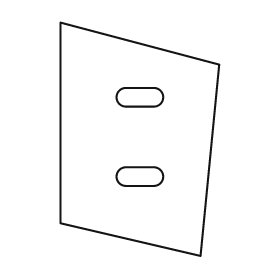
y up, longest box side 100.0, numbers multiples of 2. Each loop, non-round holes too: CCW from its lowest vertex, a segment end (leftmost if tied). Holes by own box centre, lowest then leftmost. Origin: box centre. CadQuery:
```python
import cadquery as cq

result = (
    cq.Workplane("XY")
    .moveTo(26.0, -50.0)
    .lineTo(34.0, 32.0)
    .lineTo(-34.0, 50.0)
    .lineTo(-34.0, -36.0)
    .close()
    .moveTo(-6.0, -20.0)
    .lineTo(6.0, -20.0)
    .threePointArc((10.0, -16.0), (6.0, -12.0))
    .lineTo(-6.0, -12.0)
    .threePointArc((-10.0, -16.0), (-6.0, -20.0))
    .close()
    .moveTo(-6.0, 14.0)
    .lineTo(6.0, 14.0)
    .threePointArc((10.0, 18.0), (6.0, 22.0))
    .lineTo(-6.0, 22.0)
    .threePointArc((-10.0, 18.0), (-6.0, 14.0))
    .close()
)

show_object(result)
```